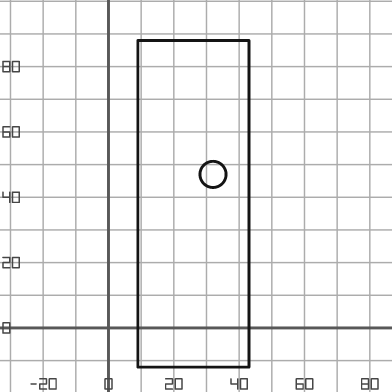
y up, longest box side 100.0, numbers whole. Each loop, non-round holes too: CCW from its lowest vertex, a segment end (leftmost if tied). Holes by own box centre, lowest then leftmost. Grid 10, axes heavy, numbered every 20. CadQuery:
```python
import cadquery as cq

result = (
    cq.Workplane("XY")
    .moveTo(9.0, -12.0)
    .lineTo(43.0, -12.0)
    .lineTo(43.0, 88.0)
    .lineTo(9.0, 88.0)
    .close()
    .moveTo(32.0, 47.0)
    .circle(4.0)
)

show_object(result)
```